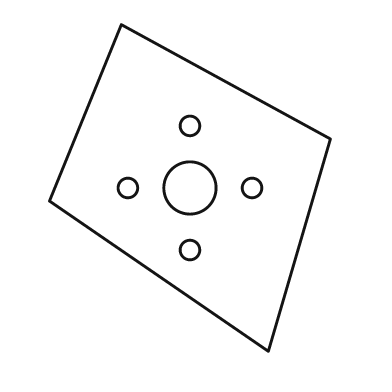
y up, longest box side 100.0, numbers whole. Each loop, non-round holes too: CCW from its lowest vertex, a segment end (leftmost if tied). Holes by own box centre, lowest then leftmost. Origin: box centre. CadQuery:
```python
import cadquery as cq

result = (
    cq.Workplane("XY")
    .moveTo(24.0, -50.0)
    .lineTo(43.0, 15.0)
    .lineTo(-21.0, 50.0)
    .lineTo(-43.0, -4.0)
    .close()
    .moveTo(0.0, -19.0)
    .circle(3.0)
    .moveTo(-19.0, 0.0)
    .circle(3.0)
    .moveTo(0.0, 0.0)
    .circle(8.0)
    .moveTo(19.0, 0.0)
    .circle(3.0)
    .moveTo(0.0, 19.0)
    .circle(3.0)
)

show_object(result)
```